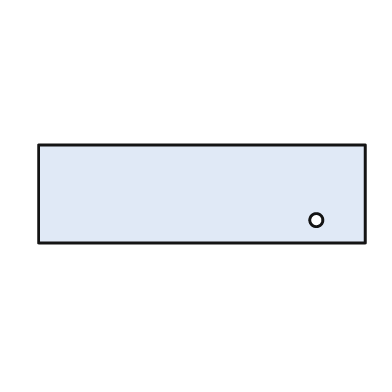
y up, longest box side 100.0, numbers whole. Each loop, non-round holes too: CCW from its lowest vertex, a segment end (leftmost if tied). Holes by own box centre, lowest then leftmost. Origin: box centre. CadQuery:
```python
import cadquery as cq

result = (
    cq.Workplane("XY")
    .moveTo(-50.0, -15.0)
    .lineTo(50.0, -15.0)
    .lineTo(50.0, 15.0)
    .lineTo(-50.0, 15.0)
    .close()
    .moveTo(35.0, -8.0)
    .circle(2.0)
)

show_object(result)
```